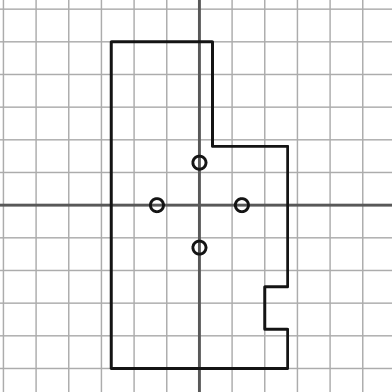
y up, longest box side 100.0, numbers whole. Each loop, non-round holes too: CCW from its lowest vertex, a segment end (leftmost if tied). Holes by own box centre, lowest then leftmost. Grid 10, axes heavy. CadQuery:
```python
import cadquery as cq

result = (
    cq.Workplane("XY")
    .moveTo(-27.0, -50.0)
    .lineTo(27.0, -50.0)
    .lineTo(27.0, -38.0)
    .lineTo(20.0, -38.0)
    .lineTo(20.0, -25.0)
    .lineTo(27.0, -25.0)
    .lineTo(27.0, 18.0)
    .lineTo(4.0, 18.0)
    .lineTo(4.0, 50.0)
    .lineTo(-27.0, 50.0)
    .close()
    .moveTo(0.0, -13.0)
    .circle(2.0)
    .moveTo(-13.0, 0.0)
    .circle(2.0)
    .moveTo(13.0, 0.0)
    .circle(2.0)
    .moveTo(0.0, 13.0)
    .circle(2.0)
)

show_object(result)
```